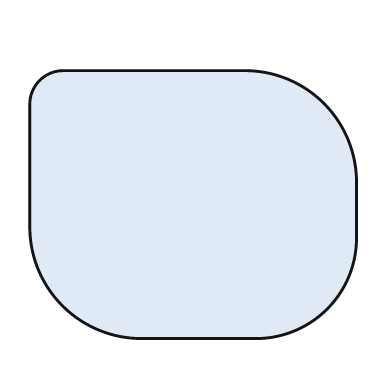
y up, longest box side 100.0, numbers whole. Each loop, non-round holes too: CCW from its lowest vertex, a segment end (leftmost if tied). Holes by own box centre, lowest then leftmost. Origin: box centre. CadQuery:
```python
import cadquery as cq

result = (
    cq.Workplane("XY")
    .moveTo(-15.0, -41.0)
    .lineTo(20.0, -41.0)
    .threePointArc((41.0, -32.0), (50.0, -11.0))
    .lineTo(50.0, 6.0)
    .threePointArc((40.0, 31.0), (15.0, 41.0))
    .lineTo(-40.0, 41.0)
    .threePointArc((-47.0, 38.0), (-50.0, 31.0))
    .lineTo(-50.0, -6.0)
    .threePointArc((-40.0, -31.0), (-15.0, -41.0))
    .close()
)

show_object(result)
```